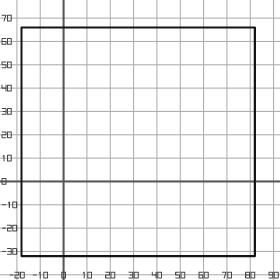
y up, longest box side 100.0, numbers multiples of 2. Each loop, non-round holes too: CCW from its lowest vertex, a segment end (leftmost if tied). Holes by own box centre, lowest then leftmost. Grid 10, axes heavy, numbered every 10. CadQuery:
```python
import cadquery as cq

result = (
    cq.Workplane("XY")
    .moveTo(-18.0, -32.0)
    .lineTo(82.0, -32.0)
    .lineTo(82.0, 66.0)
    .lineTo(-18.0, 66.0)
    .close()
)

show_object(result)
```